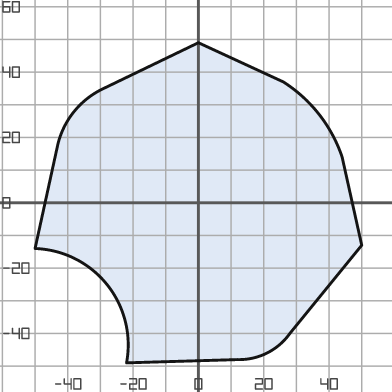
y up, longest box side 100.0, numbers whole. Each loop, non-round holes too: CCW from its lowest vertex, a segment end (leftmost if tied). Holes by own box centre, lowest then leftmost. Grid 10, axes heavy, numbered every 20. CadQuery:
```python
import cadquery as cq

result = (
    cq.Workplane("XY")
    .moveTo(-22.0, -49.0)
    .lineTo(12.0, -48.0)
    .threePointArc((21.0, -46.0), (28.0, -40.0))
    .lineTo(50.0, -13.0)
    .lineTo(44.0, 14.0)
    .threePointArc((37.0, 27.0), (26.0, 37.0))
    .lineTo(0.0, 49.0)
    .lineTo(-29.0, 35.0)
    .threePointArc((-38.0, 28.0), (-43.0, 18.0))
    .lineTo(-50.0, -14.0)
    .threePointArc((-28.0, -25.0), (-22.0, -49.0))
    .close()
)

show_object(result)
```